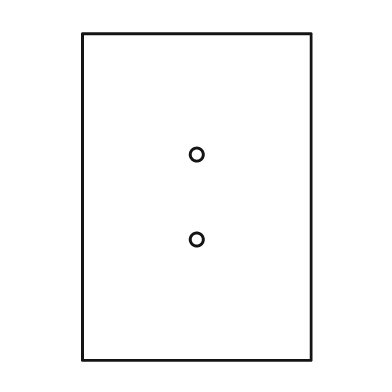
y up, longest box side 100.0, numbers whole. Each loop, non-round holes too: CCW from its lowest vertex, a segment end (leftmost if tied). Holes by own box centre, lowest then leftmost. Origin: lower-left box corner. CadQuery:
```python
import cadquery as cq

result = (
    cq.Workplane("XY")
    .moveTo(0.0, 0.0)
    .lineTo(70.0, 0.0)
    .lineTo(70.0, 100.0)
    .lineTo(0.0, 100.0)
    .close()
    .moveTo(35.0, 37.0)
    .circle(2.0)
    .moveTo(35.0, 63.0)
    .circle(2.0)
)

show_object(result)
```